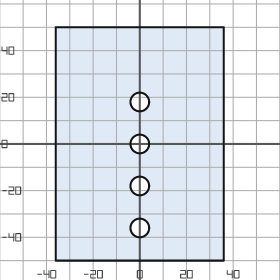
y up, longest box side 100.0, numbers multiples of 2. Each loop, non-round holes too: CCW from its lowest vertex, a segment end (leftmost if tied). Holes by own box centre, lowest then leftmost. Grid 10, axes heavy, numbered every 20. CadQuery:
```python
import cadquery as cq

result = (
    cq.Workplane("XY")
    .moveTo(-36.0, -50.0)
    .lineTo(36.0, -50.0)
    .lineTo(36.0, 50.0)
    .lineTo(-36.0, 50.0)
    .close()
    .moveTo(0.0, -36.0)
    .circle(4.0)
    .moveTo(0.0, -18.0)
    .circle(4.0)
    .moveTo(0.0, 0.0)
    .circle(4.0)
    .moveTo(0.0, 18.0)
    .circle(4.0)
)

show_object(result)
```